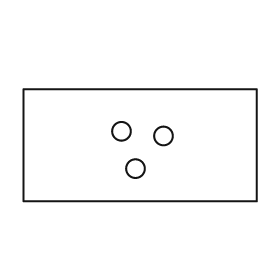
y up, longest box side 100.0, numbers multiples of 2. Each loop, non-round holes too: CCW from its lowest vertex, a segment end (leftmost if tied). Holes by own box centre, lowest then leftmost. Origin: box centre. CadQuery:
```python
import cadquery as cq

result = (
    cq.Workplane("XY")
    .moveTo(-50.0, -24.0)
    .lineTo(50.0, -24.0)
    .lineTo(50.0, 24.0)
    .lineTo(-50.0, 24.0)
    .close()
    .moveTo(-2.0, -10.0)
    .circle(4.0)
    .moveTo(10.0, 4.0)
    .circle(4.0)
    .moveTo(-8.0, 6.0)
    .circle(4.0)
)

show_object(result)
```